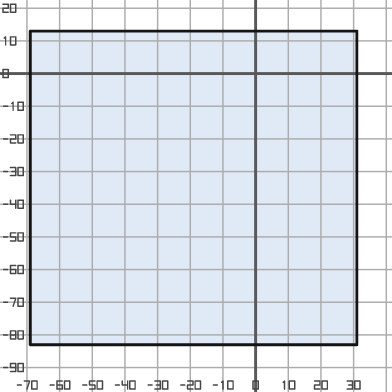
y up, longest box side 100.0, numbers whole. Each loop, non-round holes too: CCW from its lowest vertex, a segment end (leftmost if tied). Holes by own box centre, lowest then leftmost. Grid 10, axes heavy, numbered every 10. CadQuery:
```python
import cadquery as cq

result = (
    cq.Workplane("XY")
    .moveTo(-69.0, -83.0)
    .lineTo(31.0, -83.0)
    .lineTo(31.0, 13.0)
    .lineTo(-69.0, 13.0)
    .close()
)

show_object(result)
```